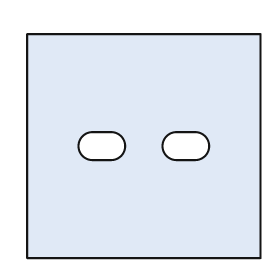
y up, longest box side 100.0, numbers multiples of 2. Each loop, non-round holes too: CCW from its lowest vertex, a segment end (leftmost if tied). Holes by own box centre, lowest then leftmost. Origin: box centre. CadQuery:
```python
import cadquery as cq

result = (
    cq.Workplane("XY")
    .moveTo(-50.0, -48.0)
    .lineTo(50.0, -48.0)
    .lineTo(50.0, 48.0)
    .lineTo(-50.0, 48.0)
    .close()
    .moveTo(-22.0, -6.0)
    .lineTo(-14.0, -6.0)
    .threePointArc((-8.0, 0.0), (-14.0, 6.0))
    .lineTo(-22.0, 6.0)
    .threePointArc((-28.0, 0.0), (-22.0, -6.0))
    .close()
    .moveTo(14.0, -6.0)
    .lineTo(22.0, -6.0)
    .threePointArc((28.0, 0.0), (22.0, 6.0))
    .lineTo(14.0, 6.0)
    .threePointArc((8.0, 0.0), (14.0, -6.0))
    .close()
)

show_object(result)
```